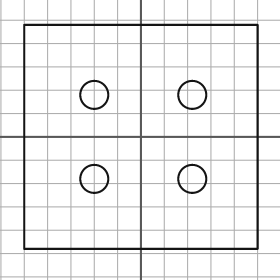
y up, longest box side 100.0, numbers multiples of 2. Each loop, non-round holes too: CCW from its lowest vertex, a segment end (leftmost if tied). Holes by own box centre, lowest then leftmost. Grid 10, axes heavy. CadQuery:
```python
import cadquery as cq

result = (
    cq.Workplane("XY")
    .moveTo(-50.0, -48.0)
    .lineTo(50.0, -48.0)
    .lineTo(50.0, 48.0)
    .lineTo(-50.0, 48.0)
    .close()
    .moveTo(-20.0, -18.0)
    .circle(6.0)
    .moveTo(22.0, -18.0)
    .circle(6.0)
    .moveTo(-20.0, 18.0)
    .circle(6.0)
    .moveTo(22.0, 18.0)
    .circle(6.0)
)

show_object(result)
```